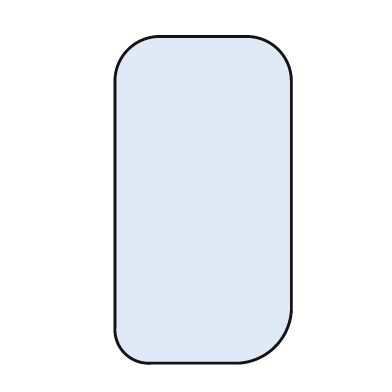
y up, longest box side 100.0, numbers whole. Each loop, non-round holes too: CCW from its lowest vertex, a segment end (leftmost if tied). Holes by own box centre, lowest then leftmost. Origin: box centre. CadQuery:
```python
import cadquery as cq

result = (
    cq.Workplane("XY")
    .moveTo(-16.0, -50.0)
    .lineTo(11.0, -50.0)
    .threePointArc((22.0, -45.0), (27.0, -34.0))
    .lineTo(27.0, 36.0)
    .threePointArc((23.0, 46.0), (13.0, 50.0))
    .lineTo(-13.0, 50.0)
    .threePointArc((-23.0, 46.0), (-27.0, 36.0))
    .lineTo(-27.0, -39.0)
    .threePointArc((-24.0, -47.0), (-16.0, -50.0))
    .close()
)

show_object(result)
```